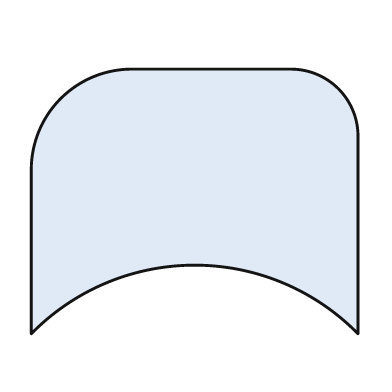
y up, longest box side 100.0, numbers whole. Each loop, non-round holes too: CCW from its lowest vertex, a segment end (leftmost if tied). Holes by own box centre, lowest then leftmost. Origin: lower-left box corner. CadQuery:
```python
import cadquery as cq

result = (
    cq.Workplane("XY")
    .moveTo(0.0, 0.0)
    .threePointArc((50.0, 21.0), (100.0, 0.0))
    .lineTo(100.0, 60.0)
    .threePointArc((94.0, 75.0), (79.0, 81.0))
    .lineTo(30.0, 81.0)
    .threePointArc((9.0, 72.0), (0.0, 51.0))
    .close()
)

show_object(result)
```